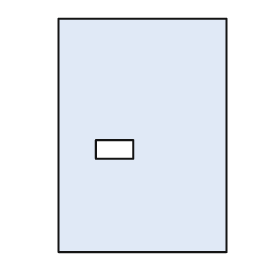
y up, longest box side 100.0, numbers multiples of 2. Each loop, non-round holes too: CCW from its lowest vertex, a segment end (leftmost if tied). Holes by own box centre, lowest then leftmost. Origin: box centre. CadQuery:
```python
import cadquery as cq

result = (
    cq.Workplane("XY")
    .moveTo(-36.0, -50.0)
    .lineTo(36.0, -50.0)
    .lineTo(36.0, 50.0)
    .lineTo(-36.0, 50.0)
    .close()
    .moveTo(-20.0, -10.0)
    .lineTo(-4.0, -10.0)
    .lineTo(-4.0, -2.0)
    .lineTo(-20.0, -2.0)
    .close()
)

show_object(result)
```